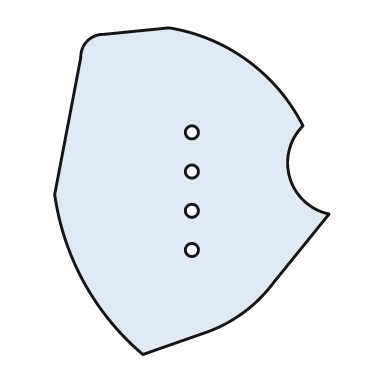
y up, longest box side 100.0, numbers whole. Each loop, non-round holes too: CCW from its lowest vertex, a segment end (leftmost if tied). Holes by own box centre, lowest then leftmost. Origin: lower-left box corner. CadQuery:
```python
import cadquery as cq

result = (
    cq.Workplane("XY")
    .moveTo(27.0, 0.0)
    .lineTo(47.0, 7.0)
    .threePointArc((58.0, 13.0), (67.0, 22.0))
    .lineTo(84.0, 43.0)
    .threePointArc((72.0, 54.0), (76.0, 70.0))
    .threePointArc((59.0, 90.0), (35.0, 100.0))
    .lineTo(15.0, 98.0)
    .threePointArc((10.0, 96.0), (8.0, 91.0))
    .lineTo(0.0, 49.0)
    .threePointArc((9.0, 22.0), (27.0, 0.0))
    .close()
    .moveTo(42.0, 32.0)
    .circle(2.0)
    .moveTo(42.0, 44.0)
    .circle(2.0)
    .moveTo(42.0, 56.0)
    .circle(2.0)
    .moveTo(42.0, 68.0)
    .circle(2.0)
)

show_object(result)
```